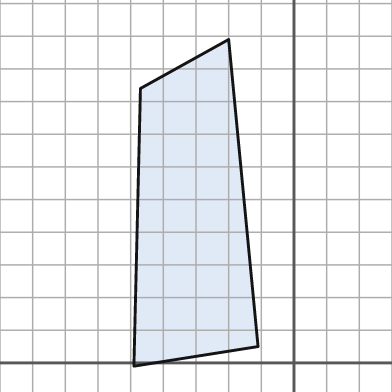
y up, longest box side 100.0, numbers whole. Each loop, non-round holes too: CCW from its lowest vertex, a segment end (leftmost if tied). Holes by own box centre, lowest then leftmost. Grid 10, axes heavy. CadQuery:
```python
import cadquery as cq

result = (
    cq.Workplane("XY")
    .moveTo(-49.0, -1.0)
    .lineTo(-11.0, 5.0)
    .lineTo(-20.0, 99.0)
    .lineTo(-47.0, 84.0)
    .close()
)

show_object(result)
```